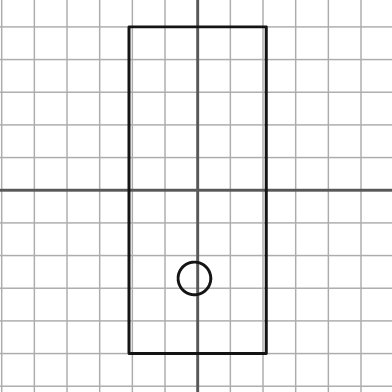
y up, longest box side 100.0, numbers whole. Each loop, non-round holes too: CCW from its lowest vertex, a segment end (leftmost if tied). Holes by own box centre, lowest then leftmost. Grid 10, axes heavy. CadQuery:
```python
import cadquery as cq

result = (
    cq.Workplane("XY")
    .moveTo(-21.0, -50.0)
    .lineTo(21.0, -50.0)
    .lineTo(21.0, 50.0)
    .lineTo(-21.0, 50.0)
    .close()
    .moveTo(-1.0, -27.0)
    .circle(5.0)
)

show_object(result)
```